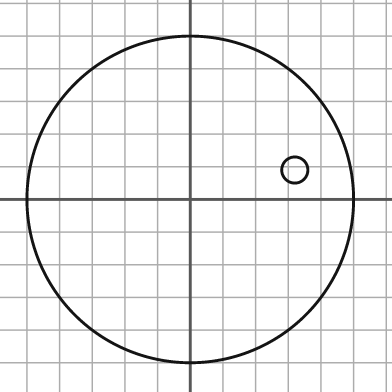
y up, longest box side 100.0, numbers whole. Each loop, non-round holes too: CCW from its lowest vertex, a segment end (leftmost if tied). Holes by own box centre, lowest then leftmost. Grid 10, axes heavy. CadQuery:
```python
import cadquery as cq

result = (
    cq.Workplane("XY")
    .moveTo(0.0, 0.0)
    .circle(50.0)
    .moveTo(32.0, 9.0)
    .circle(4.0)
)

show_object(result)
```